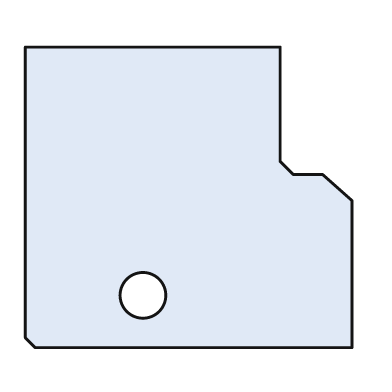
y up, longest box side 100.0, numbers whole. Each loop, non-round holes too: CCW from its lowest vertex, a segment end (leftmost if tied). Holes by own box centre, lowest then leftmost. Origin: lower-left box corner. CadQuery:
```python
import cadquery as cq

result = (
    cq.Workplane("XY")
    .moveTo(3.0, 0.0)
    .lineTo(100.0, 0.0)
    .lineTo(100.0, 45.0)
    .lineTo(91.0, 53.0)
    .lineTo(82.0, 53.0)
    .lineTo(78.0, 57.0)
    .lineTo(78.0, 92.0)
    .lineTo(0.0, 92.0)
    .lineTo(0.0, 3.0)
    .close()
    .moveTo(36.0, 16.0)
    .circle(7.0)
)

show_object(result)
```